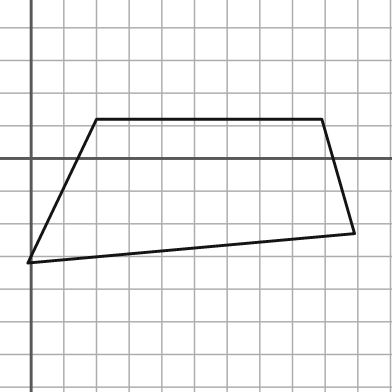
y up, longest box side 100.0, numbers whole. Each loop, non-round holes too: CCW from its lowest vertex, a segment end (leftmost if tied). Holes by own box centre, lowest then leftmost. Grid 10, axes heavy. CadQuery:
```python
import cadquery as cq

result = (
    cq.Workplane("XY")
    .moveTo(-1.0, -32.0)
    .lineTo(99.0, -23.0)
    .lineTo(89.0, 12.0)
    .lineTo(20.0, 12.0)
    .close()
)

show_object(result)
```